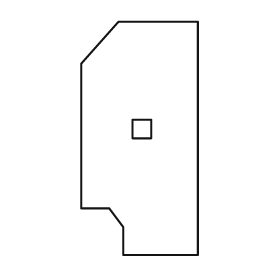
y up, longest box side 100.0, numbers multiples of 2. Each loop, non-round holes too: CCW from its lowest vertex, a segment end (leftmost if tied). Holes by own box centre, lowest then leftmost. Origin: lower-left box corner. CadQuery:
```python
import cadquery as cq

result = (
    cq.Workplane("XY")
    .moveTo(18.0, 0.0)
    .lineTo(50.0, 0.0)
    .lineTo(50.0, 100.0)
    .lineTo(16.0, 100.0)
    .lineTo(0.0, 82.0)
    .lineTo(0.0, 20.0)
    .lineTo(12.0, 20.0)
    .lineTo(18.0, 12.0)
    .close()
    .moveTo(22.0, 50.0)
    .lineTo(30.0, 50.0)
    .lineTo(30.0, 58.0)
    .lineTo(22.0, 58.0)
    .close()
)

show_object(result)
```